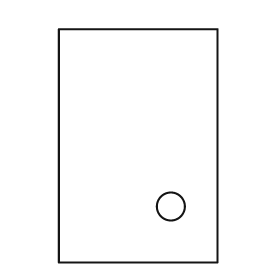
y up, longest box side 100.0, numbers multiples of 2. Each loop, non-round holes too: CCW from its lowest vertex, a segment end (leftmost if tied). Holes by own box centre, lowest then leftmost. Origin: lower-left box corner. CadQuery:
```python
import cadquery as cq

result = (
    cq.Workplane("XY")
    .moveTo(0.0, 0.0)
    .lineTo(68.0, 0.0)
    .lineTo(68.0, 100.0)
    .lineTo(0.0, 100.0)
    .close()
    .moveTo(48.0, 24.0)
    .circle(6.0)
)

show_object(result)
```